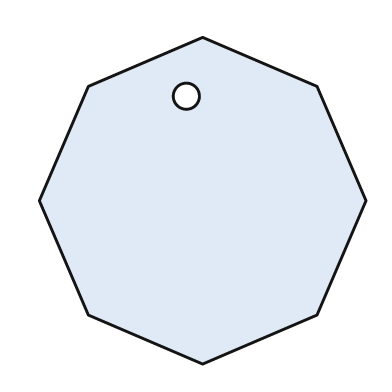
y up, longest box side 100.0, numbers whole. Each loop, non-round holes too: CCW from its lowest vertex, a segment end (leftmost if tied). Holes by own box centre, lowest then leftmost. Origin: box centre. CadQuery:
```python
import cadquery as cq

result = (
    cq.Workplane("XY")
    .moveTo(0.0, -50.0)
    .lineTo(35.0, -35.0)
    .lineTo(50.0, 0.0)
    .lineTo(35.0, 35.0)
    .lineTo(0.0, 50.0)
    .lineTo(-35.0, 35.0)
    .lineTo(-50.0, 0.0)
    .lineTo(-35.0, -35.0)
    .close()
    .moveTo(-5.0, 32.0)
    .circle(4.0)
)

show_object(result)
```